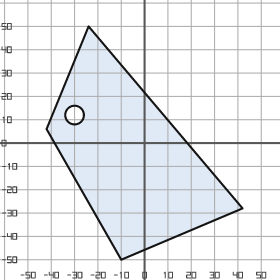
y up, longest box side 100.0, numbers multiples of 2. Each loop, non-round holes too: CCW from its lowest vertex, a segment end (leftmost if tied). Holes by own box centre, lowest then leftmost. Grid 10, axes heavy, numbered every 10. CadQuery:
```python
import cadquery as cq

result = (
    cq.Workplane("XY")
    .moveTo(-10.0, -50.0)
    .lineTo(42.0, -28.0)
    .lineTo(-24.0, 50.0)
    .lineTo(-42.0, 6.0)
    .close()
    .moveTo(-30.0, 12.0)
    .circle(4.0)
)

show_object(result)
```